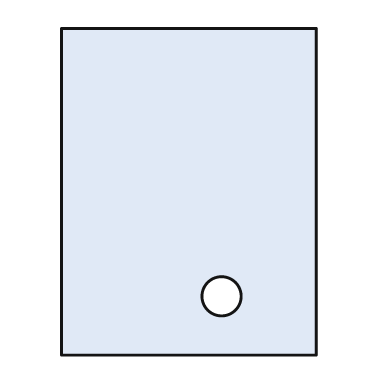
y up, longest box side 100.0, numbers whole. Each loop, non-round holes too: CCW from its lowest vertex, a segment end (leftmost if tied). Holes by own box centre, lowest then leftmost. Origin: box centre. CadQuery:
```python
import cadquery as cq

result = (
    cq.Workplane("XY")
    .moveTo(-39.0, -50.0)
    .lineTo(39.0, -50.0)
    .lineTo(39.0, 50.0)
    .lineTo(-39.0, 50.0)
    .close()
    .moveTo(10.0, -32.0)
    .circle(6.0)
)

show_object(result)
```